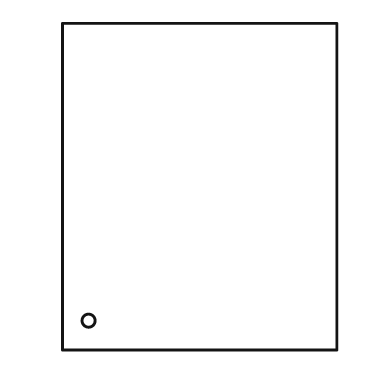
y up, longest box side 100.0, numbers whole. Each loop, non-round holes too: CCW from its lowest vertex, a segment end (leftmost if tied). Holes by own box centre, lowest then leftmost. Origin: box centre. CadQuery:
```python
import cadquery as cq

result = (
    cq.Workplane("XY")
    .moveTo(-42.0, -50.0)
    .lineTo(42.0, -50.0)
    .lineTo(42.0, 50.0)
    .lineTo(-42.0, 50.0)
    .close()
    .moveTo(-34.0, -41.0)
    .circle(2.0)
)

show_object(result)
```